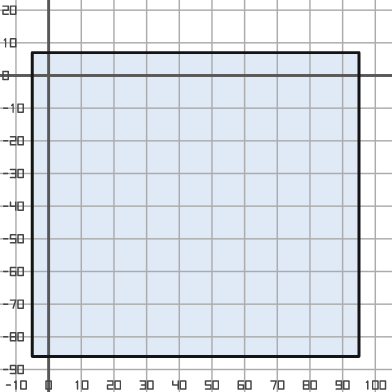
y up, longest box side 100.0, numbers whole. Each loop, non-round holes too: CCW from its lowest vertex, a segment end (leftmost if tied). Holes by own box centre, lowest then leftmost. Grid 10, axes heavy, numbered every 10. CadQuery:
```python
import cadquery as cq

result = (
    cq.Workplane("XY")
    .moveTo(-5.0, -86.0)
    .lineTo(95.0, -86.0)
    .lineTo(95.0, 7.0)
    .lineTo(-5.0, 7.0)
    .close()
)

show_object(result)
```